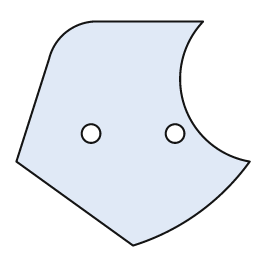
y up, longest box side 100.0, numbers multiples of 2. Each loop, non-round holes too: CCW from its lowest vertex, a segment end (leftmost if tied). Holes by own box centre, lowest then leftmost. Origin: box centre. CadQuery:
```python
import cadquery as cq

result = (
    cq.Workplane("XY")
    .moveTo(0.0, -48.0)
    .threePointArc((28.0, -34.0), (50.0, -12.0))
    .threePointArc((22.0, 12.0), (30.0, 48.0))
    .lineTo(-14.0, 48.0)
    .threePointArc((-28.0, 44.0), (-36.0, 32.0))
    .lineTo(-50.0, -12.0)
    .close()
    .moveTo(-18.0, 0.0)
    .circle(4.0)
    .moveTo(18.0, 0.0)
    .circle(4.0)
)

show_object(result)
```